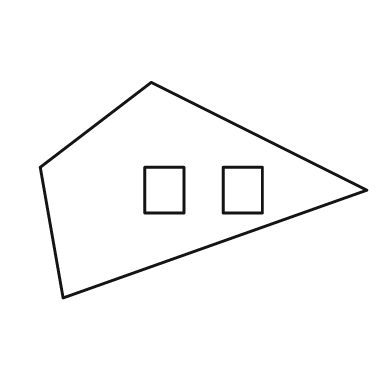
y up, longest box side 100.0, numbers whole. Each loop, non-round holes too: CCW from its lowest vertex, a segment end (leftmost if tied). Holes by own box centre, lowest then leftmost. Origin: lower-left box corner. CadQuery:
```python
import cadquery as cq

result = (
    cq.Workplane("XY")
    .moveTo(7.0, 0.0)
    .lineTo(100.0, 33.0)
    .lineTo(34.0, 66.0)
    .lineTo(0.0, 40.0)
    .close()
    .moveTo(32.0, 26.0)
    .lineTo(44.0, 26.0)
    .lineTo(44.0, 40.0)
    .lineTo(32.0, 40.0)
    .close()
    .moveTo(56.0, 26.0)
    .lineTo(68.0, 26.0)
    .lineTo(68.0, 40.0)
    .lineTo(56.0, 40.0)
    .close()
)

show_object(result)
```